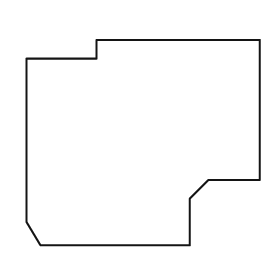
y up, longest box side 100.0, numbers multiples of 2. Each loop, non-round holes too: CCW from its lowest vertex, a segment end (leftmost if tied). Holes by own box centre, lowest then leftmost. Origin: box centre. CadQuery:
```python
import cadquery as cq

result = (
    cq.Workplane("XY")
    .moveTo(-44.0, -44.0)
    .lineTo(20.0, -44.0)
    .lineTo(20.0, -24.0)
    .lineTo(28.0, -16.0)
    .lineTo(50.0, -16.0)
    .lineTo(50.0, 44.0)
    .lineTo(-20.0, 44.0)
    .lineTo(-20.0, 36.0)
    .lineTo(-50.0, 36.0)
    .lineTo(-50.0, -34.0)
    .close()
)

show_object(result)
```